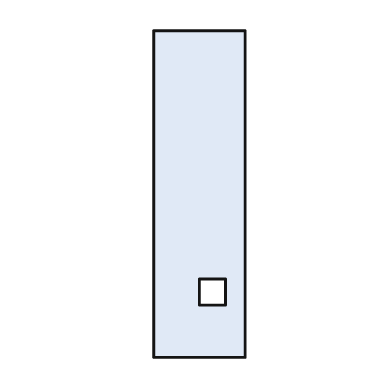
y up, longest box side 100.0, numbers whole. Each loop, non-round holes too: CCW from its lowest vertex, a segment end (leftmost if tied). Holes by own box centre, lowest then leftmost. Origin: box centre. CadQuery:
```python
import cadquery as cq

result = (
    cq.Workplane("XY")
    .moveTo(-14.0, -50.0)
    .lineTo(14.0, -50.0)
    .lineTo(14.0, 50.0)
    .lineTo(-14.0, 50.0)
    .close()
    .moveTo(0.0, -34.0)
    .lineTo(8.0, -34.0)
    .lineTo(8.0, -26.0)
    .lineTo(0.0, -26.0)
    .close()
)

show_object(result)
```